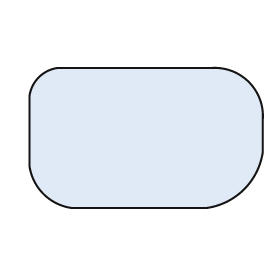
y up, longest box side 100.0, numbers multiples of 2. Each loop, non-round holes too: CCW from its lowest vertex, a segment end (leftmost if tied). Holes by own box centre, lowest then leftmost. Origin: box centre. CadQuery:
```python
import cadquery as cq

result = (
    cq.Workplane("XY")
    .moveTo(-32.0, -30.0)
    .lineTo(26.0, -30.0)
    .threePointArc((42.0, -22.0), (50.0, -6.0))
    .lineTo(50.0, 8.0)
    .threePointArc((44.0, 24.0), (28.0, 30.0))
    .lineTo(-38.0, 30.0)
    .threePointArc((-46.0, 26.0), (-50.0, 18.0))
    .lineTo(-50.0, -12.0)
    .threePointArc((-44.0, -24.0), (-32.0, -30.0))
    .close()
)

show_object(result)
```